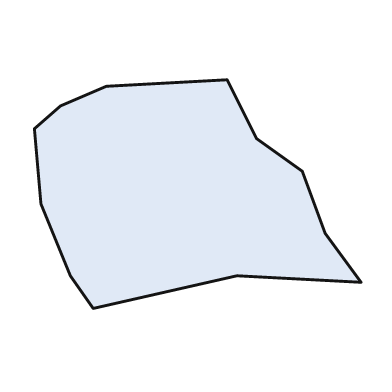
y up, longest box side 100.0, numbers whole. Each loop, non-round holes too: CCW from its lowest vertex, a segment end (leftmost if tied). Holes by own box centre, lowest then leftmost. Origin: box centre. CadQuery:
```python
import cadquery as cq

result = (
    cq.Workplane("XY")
    .moveTo(-32.0, -35.0)
    .lineTo(12.0, -25.0)
    .lineTo(50.0, -27.0)
    .lineTo(39.0, -12.0)
    .lineTo(32.0, 7.0)
    .lineTo(18.0, 17.0)
    .lineTo(9.0, 35.0)
    .lineTo(-28.0, 33.0)
    .lineTo(-42.0, 27.0)
    .lineTo(-50.0, 20.0)
    .lineTo(-48.0, -3.0)
    .lineTo(-39.0, -25.0)
    .close()
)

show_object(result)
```